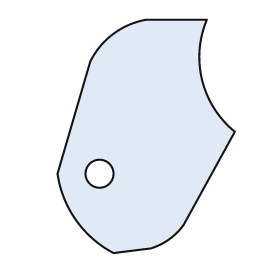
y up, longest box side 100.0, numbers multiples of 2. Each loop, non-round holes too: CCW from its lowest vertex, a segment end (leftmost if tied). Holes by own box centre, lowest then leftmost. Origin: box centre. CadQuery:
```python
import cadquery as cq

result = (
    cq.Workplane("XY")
    .moveTo(-14.0, -50.0)
    .lineTo(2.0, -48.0)
    .threePointArc((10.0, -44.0), (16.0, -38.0))
    .lineTo(38.0, 2.0)
    .threePointArc((24.0, 24.0), (26.0, 50.0))
    .lineTo(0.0, 50.0)
    .threePointArc((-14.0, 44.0), (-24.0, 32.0))
    .lineTo(-38.0, -16.0)
    .threePointArc((-30.0, -36.0), (-14.0, -50.0))
    .close()
    .moveTo(-20.0, -16.0)
    .circle(6.0)
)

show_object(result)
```